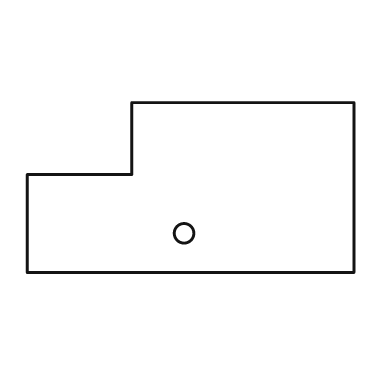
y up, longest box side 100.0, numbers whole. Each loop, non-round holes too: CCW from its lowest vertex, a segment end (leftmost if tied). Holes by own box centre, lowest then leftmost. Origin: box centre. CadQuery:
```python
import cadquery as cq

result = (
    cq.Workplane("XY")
    .moveTo(-50.0, -26.0)
    .lineTo(50.0, -26.0)
    .lineTo(50.0, 26.0)
    .lineTo(-18.0, 26.0)
    .lineTo(-18.0, 4.0)
    .lineTo(-50.0, 4.0)
    .close()
    .moveTo(-2.0, -14.0)
    .circle(3.0)
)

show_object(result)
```